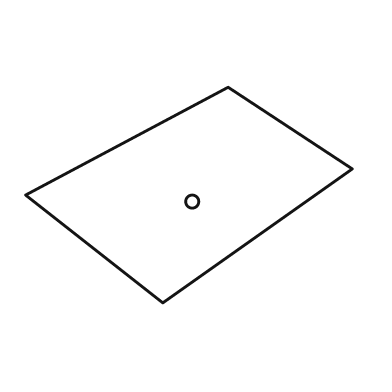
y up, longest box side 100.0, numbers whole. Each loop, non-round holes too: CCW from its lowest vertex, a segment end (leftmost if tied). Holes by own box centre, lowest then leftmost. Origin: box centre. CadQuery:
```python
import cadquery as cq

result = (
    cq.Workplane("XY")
    .moveTo(-8.0, -33.0)
    .lineTo(50.0, 8.0)
    .lineTo(12.0, 33.0)
    .lineTo(-50.0, 0.0)
    .close()
    .moveTo(1.0, -2.0)
    .circle(2.0)
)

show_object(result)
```